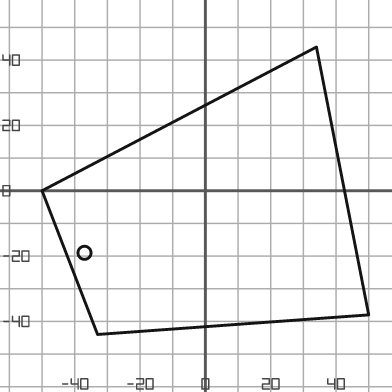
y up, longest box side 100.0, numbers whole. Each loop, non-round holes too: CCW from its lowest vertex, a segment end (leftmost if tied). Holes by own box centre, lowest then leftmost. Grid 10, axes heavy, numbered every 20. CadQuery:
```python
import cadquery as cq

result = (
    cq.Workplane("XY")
    .moveTo(-33.0, -44.0)
    .lineTo(50.0, -38.0)
    .lineTo(34.0, 44.0)
    .lineTo(-50.0, 0.0)
    .close()
    .moveTo(-37.0, -19.0)
    .circle(2.0)
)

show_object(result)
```